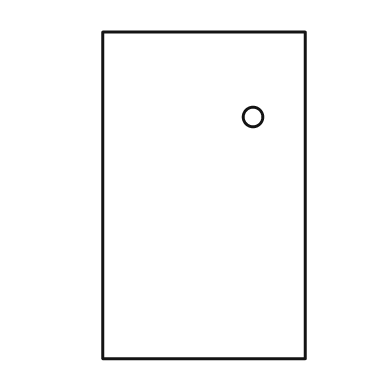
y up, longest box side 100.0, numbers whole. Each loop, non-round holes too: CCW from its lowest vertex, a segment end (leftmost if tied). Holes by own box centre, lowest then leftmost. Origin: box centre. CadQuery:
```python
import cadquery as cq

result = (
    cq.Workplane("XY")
    .moveTo(-31.0, -50.0)
    .lineTo(31.0, -50.0)
    .lineTo(31.0, 50.0)
    .lineTo(-31.0, 50.0)
    .close()
    .moveTo(15.0, 24.0)
    .circle(3.0)
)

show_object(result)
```